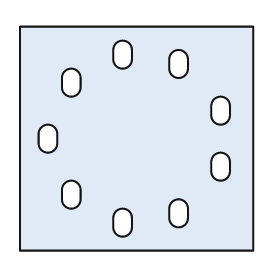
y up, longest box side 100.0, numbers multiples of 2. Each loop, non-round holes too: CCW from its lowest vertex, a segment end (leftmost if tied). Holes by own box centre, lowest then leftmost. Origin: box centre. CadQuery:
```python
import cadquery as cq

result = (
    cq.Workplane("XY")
    .moveTo(-50.0, -48.0)
    .lineTo(50.0, -48.0)
    .lineTo(50.0, 48.0)
    .lineTo(-50.0, 48.0)
    .close()
    .moveTo(-10.0, -38.0)
    .threePointArc((-6.0, -42.0), (-2.0, -38.0))
    .lineTo(-2.0, -34.0)
    .threePointArc((-6.0, -30.0), (-10.0, -34.0))
    .close()
    .moveTo(14.0, -34.0)
    .threePointArc((18.0, -38.0), (22.0, -34.0))
    .lineTo(22.0, -30.0)
    .threePointArc((18.0, -26.0), (14.0, -30.0))
    .close()
    .moveTo(-32.0, -26.0)
    .threePointArc((-28.0, -30.0), (-24.0, -26.0))
    .lineTo(-24.0, -22.0)
    .threePointArc((-28.0, -18.0), (-32.0, -22.0))
    .close()
    .moveTo(32.0, -14.0)
    .threePointArc((36.0, -18.0), (40.0, -14.0))
    .lineTo(40.0, -10.0)
    .threePointArc((36.0, -6.0), (32.0, -10.0))
    .close()
    .moveTo(-42.0, -2.0)
    .threePointArc((-38.0, -6.0), (-34.0, -2.0))
    .lineTo(-34.0, 2.0)
    .threePointArc((-38.0, 6.0), (-42.0, 2.0))
    .close()
    .moveTo(32.0, 10.0)
    .threePointArc((36.0, 6.0), (40.0, 10.0))
    .lineTo(40.0, 14.0)
    .threePointArc((36.0, 18.0), (32.0, 14.0))
    .close()
    .moveTo(-32.0, 22.0)
    .threePointArc((-28.0, 18.0), (-24.0, 22.0))
    .lineTo(-24.0, 26.0)
    .threePointArc((-28.0, 30.0), (-32.0, 26.0))
    .close()
    .moveTo(14.0, 30.0)
    .threePointArc((18.0, 26.0), (22.0, 30.0))
    .lineTo(22.0, 34.0)
    .threePointArc((18.0, 38.0), (14.0, 34.0))
    .close()
    .moveTo(-10.0, 34.0)
    .threePointArc((-6.0, 30.0), (-2.0, 34.0))
    .lineTo(-2.0, 38.0)
    .threePointArc((-6.0, 42.0), (-10.0, 38.0))
    .close()
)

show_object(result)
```